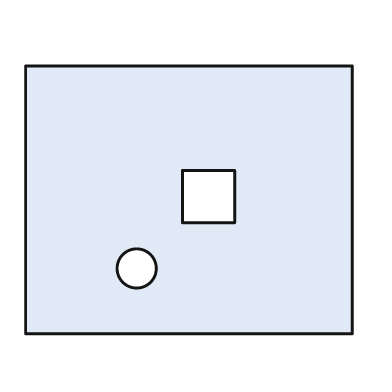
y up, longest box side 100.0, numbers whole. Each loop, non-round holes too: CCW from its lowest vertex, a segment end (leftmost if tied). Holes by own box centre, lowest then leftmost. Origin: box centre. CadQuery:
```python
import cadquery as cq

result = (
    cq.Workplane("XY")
    .moveTo(-50.0, -41.0)
    .lineTo(50.0, -41.0)
    .lineTo(50.0, 41.0)
    .lineTo(-50.0, 41.0)
    .close()
    .moveTo(-16.0, -21.0)
    .circle(6.0)
    .moveTo(-2.0, -7.0)
    .lineTo(14.0, -7.0)
    .lineTo(14.0, 9.0)
    .lineTo(-2.0, 9.0)
    .close()
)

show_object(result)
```